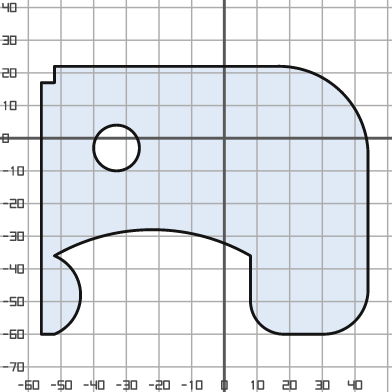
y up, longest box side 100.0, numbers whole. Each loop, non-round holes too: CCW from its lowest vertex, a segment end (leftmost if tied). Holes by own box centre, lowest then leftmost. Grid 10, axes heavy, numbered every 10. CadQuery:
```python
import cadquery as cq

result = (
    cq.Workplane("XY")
    .moveTo(-56.0, -60.0)
    .lineTo(-52.0, -60.0)
    .threePointArc((-44.0, -48.0), (-52.0, -36.0))
    .threePointArc((-22.0, -28.0), (8.0, -36.0))
    .lineTo(8.0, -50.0)
    .threePointArc((11.0, -57.0), (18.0, -60.0))
    .lineTo(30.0, -60.0)
    .threePointArc((40.0, -56.0), (44.0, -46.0))
    .lineTo(44.0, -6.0)
    .threePointArc((36.0, 14.0), (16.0, 22.0))
    .lineTo(-52.0, 22.0)
    .lineTo(-52.0, 17.0)
    .lineTo(-56.0, 17.0)
    .close()
    .moveTo(-33.0, -3.0)
    .circle(7.0)
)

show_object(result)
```